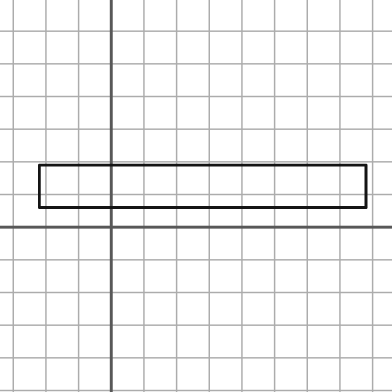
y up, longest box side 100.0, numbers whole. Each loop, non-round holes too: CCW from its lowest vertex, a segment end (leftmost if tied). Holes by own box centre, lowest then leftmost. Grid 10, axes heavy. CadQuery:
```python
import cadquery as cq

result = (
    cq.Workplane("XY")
    .moveTo(-22.0, 6.0)
    .lineTo(78.0, 6.0)
    .lineTo(78.0, 19.0)
    .lineTo(-22.0, 19.0)
    .close()
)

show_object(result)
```